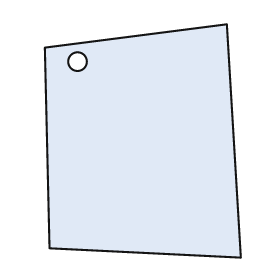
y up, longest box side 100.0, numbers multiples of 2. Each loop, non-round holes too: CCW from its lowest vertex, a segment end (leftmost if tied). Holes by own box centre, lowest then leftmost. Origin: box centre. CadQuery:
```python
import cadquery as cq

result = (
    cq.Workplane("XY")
    .moveTo(42.0, -50.0)
    .lineTo(36.0, 50.0)
    .lineTo(-42.0, 40.0)
    .lineTo(-40.0, -46.0)
    .close()
    .moveTo(-28.0, 34.0)
    .circle(4.0)
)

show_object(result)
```